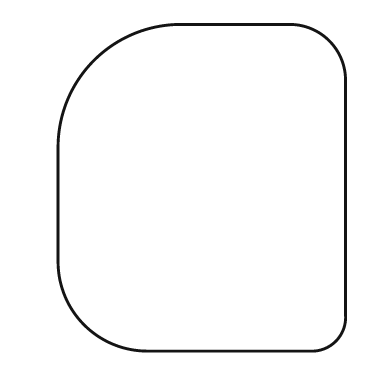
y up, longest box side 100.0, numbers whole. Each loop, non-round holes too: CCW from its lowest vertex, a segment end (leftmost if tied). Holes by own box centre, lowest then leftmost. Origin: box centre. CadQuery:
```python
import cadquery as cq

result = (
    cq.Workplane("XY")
    .moveTo(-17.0, -50.0)
    .lineTo(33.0, -50.0)
    .threePointArc((41.0, -47.0), (44.0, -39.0))
    .lineTo(44.0, 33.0)
    .threePointArc((39.0, 45.0), (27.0, 50.0))
    .lineTo(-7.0, 50.0)
    .threePointArc((-33.0, 39.0), (-44.0, 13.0))
    .lineTo(-44.0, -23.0)
    .threePointArc((-36.0, -42.0), (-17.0, -50.0))
    .close()
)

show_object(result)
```